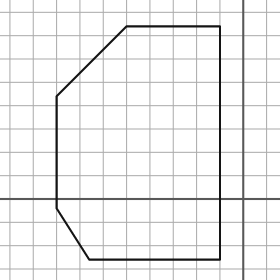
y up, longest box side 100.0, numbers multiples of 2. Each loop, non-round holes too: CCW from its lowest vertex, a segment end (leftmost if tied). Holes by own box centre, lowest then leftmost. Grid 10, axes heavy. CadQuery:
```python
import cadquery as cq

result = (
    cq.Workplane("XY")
    .moveTo(-66.0, -26.0)
    .lineTo(-10.0, -26.0)
    .lineTo(-10.0, 74.0)
    .lineTo(-50.0, 74.0)
    .lineTo(-80.0, 44.0)
    .lineTo(-80.0, -4.0)
    .close()
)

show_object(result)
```